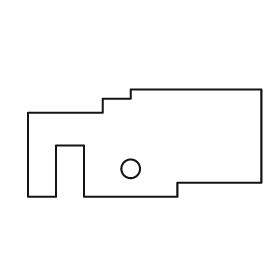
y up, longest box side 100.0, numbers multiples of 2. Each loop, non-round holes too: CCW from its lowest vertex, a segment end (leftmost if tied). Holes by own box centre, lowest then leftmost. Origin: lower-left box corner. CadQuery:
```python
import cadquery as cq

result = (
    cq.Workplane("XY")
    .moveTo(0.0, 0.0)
    .lineTo(12.0, 0.0)
    .lineTo(12.0, 22.0)
    .lineTo(24.0, 22.0)
    .lineTo(24.0, 0.0)
    .lineTo(64.0, 0.0)
    .lineTo(64.0, 6.0)
    .lineTo(100.0, 6.0)
    .lineTo(100.0, 46.0)
    .lineTo(44.0, 46.0)
    .lineTo(44.0, 42.0)
    .lineTo(32.0, 42.0)
    .lineTo(32.0, 36.0)
    .lineTo(0.0, 36.0)
    .close()
    .moveTo(44.0, 12.0)
    .circle(4.0)
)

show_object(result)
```